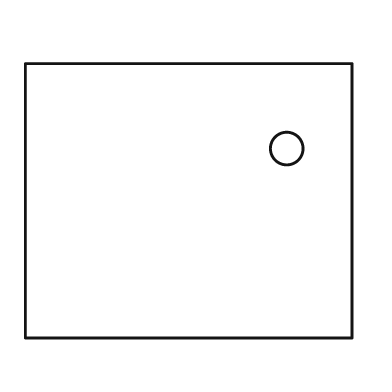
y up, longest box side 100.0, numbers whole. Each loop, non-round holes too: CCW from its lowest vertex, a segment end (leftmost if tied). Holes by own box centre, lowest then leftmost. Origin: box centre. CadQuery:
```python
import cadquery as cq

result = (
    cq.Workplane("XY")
    .moveTo(-50.0, -42.0)
    .lineTo(50.0, -42.0)
    .lineTo(50.0, 42.0)
    .lineTo(-50.0, 42.0)
    .close()
    .moveTo(30.0, 16.0)
    .circle(5.0)
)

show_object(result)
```